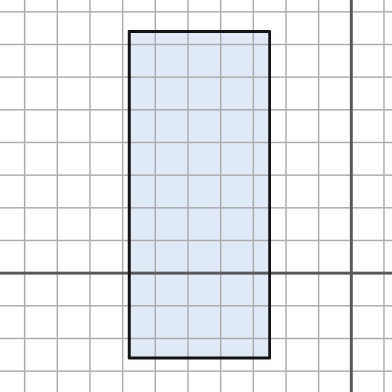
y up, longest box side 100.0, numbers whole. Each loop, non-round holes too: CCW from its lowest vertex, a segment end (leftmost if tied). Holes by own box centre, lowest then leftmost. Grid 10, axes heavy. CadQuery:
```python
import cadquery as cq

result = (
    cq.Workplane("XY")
    .moveTo(-68.0, -26.0)
    .lineTo(-25.0, -26.0)
    .lineTo(-25.0, 74.0)
    .lineTo(-68.0, 74.0)
    .close()
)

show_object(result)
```